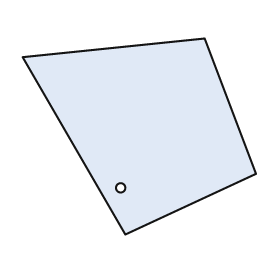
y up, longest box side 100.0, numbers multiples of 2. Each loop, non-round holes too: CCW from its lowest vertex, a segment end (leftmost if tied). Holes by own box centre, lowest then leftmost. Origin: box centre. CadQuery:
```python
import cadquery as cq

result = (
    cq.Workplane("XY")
    .moveTo(-6.0, -42.0)
    .lineTo(50.0, -16.0)
    .lineTo(28.0, 42.0)
    .lineTo(-50.0, 34.0)
    .close()
    .moveTo(-8.0, -22.0)
    .circle(2.0)
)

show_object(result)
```